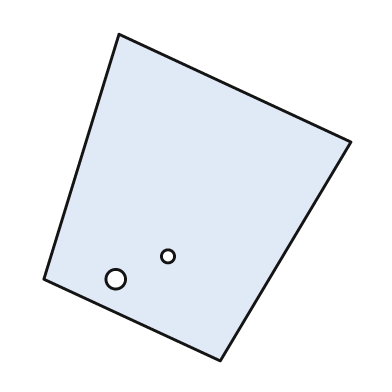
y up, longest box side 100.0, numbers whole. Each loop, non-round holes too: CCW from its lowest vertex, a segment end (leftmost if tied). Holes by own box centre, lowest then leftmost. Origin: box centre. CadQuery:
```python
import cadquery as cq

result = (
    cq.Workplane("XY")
    .moveTo(7.0, -50.0)
    .lineTo(47.0, 17.0)
    .lineTo(-24.0, 50.0)
    .lineTo(-47.0, -25.0)
    .close()
    .moveTo(-25.0, -25.0)
    .circle(3.0)
    .moveTo(-9.0, -18.0)
    .circle(2.0)
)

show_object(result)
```